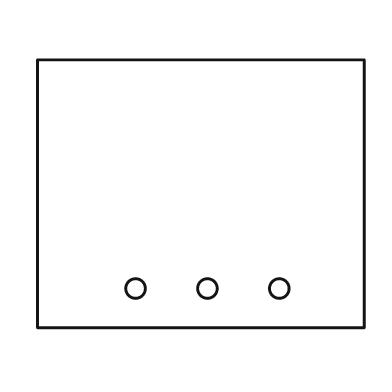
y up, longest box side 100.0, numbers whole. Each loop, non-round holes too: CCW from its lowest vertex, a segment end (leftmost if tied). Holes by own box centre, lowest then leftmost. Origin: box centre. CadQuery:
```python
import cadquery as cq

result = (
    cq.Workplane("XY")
    .moveTo(-50.0, -41.0)
    .lineTo(50.0, -41.0)
    .lineTo(50.0, 41.0)
    .lineTo(-50.0, 41.0)
    .close()
    .moveTo(-20.0, -29.0)
    .circle(3.0)
    .moveTo(2.0, -29.0)
    .circle(3.0)
    .moveTo(24.0, -29.0)
    .circle(3.0)
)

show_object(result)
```